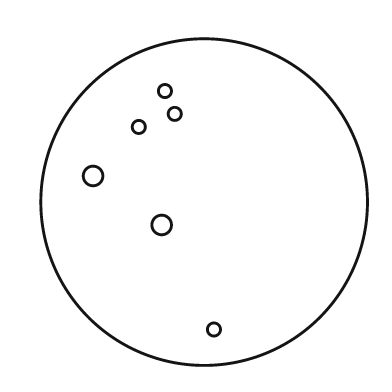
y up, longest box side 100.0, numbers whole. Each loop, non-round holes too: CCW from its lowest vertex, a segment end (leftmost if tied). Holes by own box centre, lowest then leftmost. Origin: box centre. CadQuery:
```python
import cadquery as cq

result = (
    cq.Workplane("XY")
    .moveTo(0.0, 0.0)
    .circle(50.0)
    .moveTo(3.0, -39.0)
    .circle(2.0)
    .moveTo(-13.0, -7.0)
    .circle(3.0)
    .moveTo(-34.0, 8.0)
    .circle(3.0)
    .moveTo(-20.0, 23.0)
    .circle(2.0)
    .moveTo(-9.0, 27.0)
    .circle(2.0)
    .moveTo(-12.0, 34.0)
    .circle(2.0)
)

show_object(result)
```